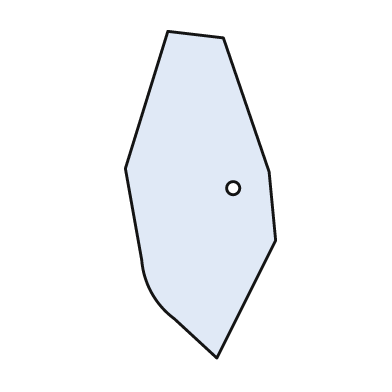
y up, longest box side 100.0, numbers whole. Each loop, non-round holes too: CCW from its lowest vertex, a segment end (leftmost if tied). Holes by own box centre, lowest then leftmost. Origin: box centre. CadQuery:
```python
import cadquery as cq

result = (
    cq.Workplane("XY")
    .moveTo(5.0, -50.0)
    .lineTo(23.0, -14.0)
    .lineTo(21.0, 7.0)
    .lineTo(7.0, 48.0)
    .lineTo(-10.0, 50.0)
    .lineTo(-23.0, 8.0)
    .lineTo(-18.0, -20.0)
    .threePointArc((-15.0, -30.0), (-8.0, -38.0))
    .close()
    .moveTo(10.0, 2.0)
    .circle(2.0)
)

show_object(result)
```